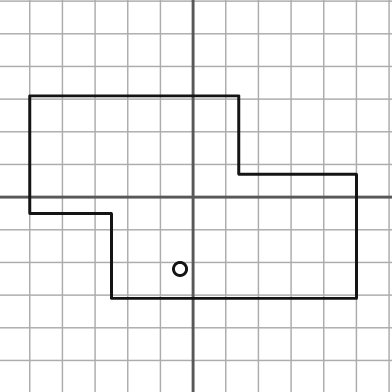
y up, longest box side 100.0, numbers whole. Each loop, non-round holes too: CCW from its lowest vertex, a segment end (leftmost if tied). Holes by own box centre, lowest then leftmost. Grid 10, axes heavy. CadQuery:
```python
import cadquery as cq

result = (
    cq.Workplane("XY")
    .moveTo(-25.0, -31.0)
    .lineTo(50.0, -31.0)
    .lineTo(50.0, 7.0)
    .lineTo(14.0, 7.0)
    .lineTo(14.0, 31.0)
    .lineTo(-50.0, 31.0)
    .lineTo(-50.0, -5.0)
    .lineTo(-25.0, -5.0)
    .close()
    .moveTo(-4.0, -22.0)
    .circle(2.0)
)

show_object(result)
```